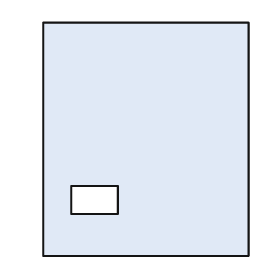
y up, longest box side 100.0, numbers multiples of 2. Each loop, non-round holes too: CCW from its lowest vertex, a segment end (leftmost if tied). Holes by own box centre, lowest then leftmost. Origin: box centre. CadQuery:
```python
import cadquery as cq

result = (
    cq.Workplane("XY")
    .moveTo(-44.0, -50.0)
    .lineTo(44.0, -50.0)
    .lineTo(44.0, 50.0)
    .lineTo(-44.0, 50.0)
    .close()
    .moveTo(-32.0, -32.0)
    .lineTo(-12.0, -32.0)
    .lineTo(-12.0, -20.0)
    .lineTo(-32.0, -20.0)
    .close()
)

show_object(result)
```